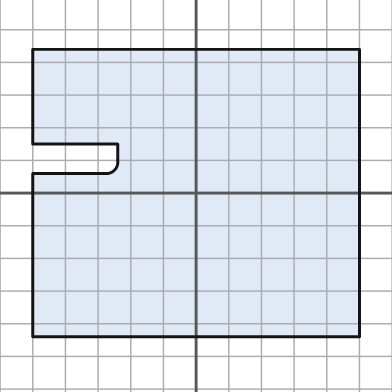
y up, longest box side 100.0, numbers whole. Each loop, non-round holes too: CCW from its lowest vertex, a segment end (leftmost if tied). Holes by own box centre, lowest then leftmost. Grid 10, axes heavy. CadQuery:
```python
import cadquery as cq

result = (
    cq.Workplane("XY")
    .moveTo(-50.0, -44.0)
    .lineTo(50.0, -44.0)
    .lineTo(50.0, 44.0)
    .lineTo(-50.0, 44.0)
    .lineTo(-50.0, 15.0)
    .lineTo(-24.0, 15.0)
    .lineTo(-24.0, 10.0)
    .threePointArc((-25.0, 7.0), (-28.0, 6.0))
    .lineTo(-50.0, 6.0)
    .close()
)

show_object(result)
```